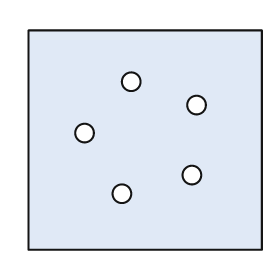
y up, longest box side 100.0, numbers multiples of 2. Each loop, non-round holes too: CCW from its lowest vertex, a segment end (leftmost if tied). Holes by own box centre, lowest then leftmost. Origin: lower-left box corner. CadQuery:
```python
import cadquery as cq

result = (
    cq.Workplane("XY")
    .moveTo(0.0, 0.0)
    .lineTo(100.0, 0.0)
    .lineTo(100.0, 94.0)
    .lineTo(0.0, 94.0)
    .close()
    .moveTo(40.0, 24.0)
    .circle(4.0)
    .moveTo(70.0, 32.0)
    .circle(4.0)
    .moveTo(24.0, 50.0)
    .circle(4.0)
    .moveTo(72.0, 62.0)
    .circle(4.0)
    .moveTo(44.0, 72.0)
    .circle(4.0)
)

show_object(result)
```